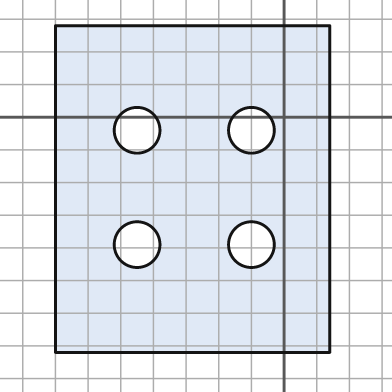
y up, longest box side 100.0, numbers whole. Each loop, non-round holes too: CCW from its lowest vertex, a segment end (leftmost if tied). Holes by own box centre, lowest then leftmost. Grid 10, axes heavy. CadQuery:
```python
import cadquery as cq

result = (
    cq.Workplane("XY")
    .moveTo(-70.0, -72.0)
    .lineTo(14.0, -72.0)
    .lineTo(14.0, 28.0)
    .lineTo(-70.0, 28.0)
    .close()
    .moveTo(-45.0, -39.0)
    .circle(7.0)
    .moveTo(-10.0, -39.0)
    .circle(7.0)
    .moveTo(-45.0, -4.0)
    .circle(7.0)
    .moveTo(-10.0, -4.0)
    .circle(7.0)
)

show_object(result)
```